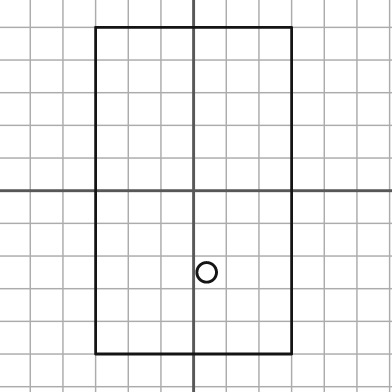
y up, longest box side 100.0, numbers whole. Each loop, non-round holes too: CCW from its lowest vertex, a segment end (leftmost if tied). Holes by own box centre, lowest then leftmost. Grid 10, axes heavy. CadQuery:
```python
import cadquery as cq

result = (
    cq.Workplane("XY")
    .moveTo(-30.0, -50.0)
    .lineTo(30.0, -50.0)
    .lineTo(30.0, 50.0)
    .lineTo(-30.0, 50.0)
    .close()
    .moveTo(4.0, -25.0)
    .circle(3.0)
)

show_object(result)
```